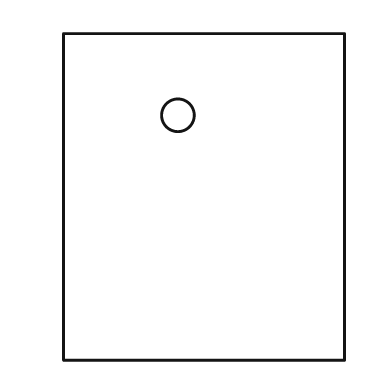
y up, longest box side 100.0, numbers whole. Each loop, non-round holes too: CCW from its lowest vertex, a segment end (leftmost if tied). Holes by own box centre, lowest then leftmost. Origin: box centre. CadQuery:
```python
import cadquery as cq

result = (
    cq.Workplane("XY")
    .moveTo(-43.0, -50.0)
    .lineTo(43.0, -50.0)
    .lineTo(43.0, 50.0)
    .lineTo(-43.0, 50.0)
    .close()
    .moveTo(-8.0, 25.0)
    .circle(5.0)
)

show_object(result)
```